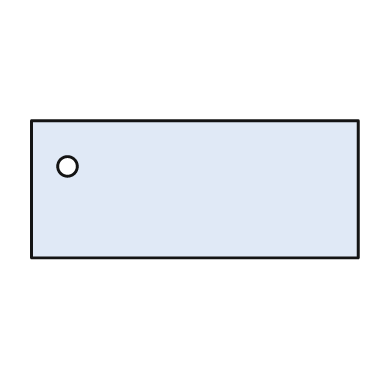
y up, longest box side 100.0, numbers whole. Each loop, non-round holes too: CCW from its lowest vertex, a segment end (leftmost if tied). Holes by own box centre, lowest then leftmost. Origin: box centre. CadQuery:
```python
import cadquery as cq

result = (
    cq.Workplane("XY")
    .moveTo(-50.0, -21.0)
    .lineTo(50.0, -21.0)
    .lineTo(50.0, 21.0)
    .lineTo(-50.0, 21.0)
    .close()
    .moveTo(-39.0, 7.0)
    .circle(3.0)
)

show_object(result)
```